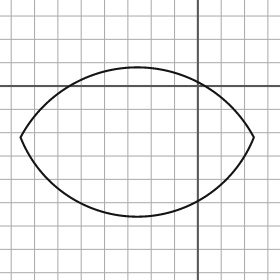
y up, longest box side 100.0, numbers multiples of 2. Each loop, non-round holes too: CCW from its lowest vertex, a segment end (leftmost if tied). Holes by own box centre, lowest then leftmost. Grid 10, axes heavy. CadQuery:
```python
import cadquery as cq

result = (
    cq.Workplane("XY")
    .moveTo(-76.0, -22.0)
    .threePointArc((-26.0, -56.0), (24.0, -22.0))
    .threePointArc((-26.0, 8.0), (-76.0, -22.0))
    .close()
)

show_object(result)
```